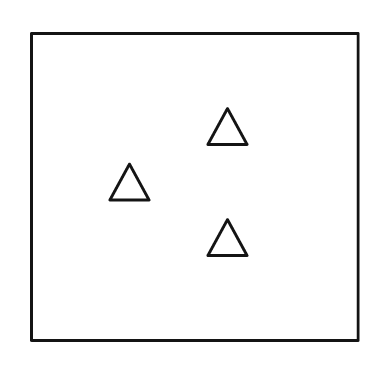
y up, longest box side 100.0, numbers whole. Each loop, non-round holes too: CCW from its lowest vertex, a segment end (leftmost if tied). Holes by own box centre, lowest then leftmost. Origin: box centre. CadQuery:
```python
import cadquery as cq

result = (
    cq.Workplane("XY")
    .moveTo(-50.0, -47.0)
    .lineTo(50.0, -47.0)
    .lineTo(50.0, 47.0)
    .lineTo(-50.0, 47.0)
    .close()
    .moveTo(4.0, -21.0)
    .lineTo(16.0, -21.0)
    .lineTo(10.0, -10.0)
    .close()
    .moveTo(-26.0, -4.0)
    .lineTo(-14.0, -4.0)
    .lineTo(-20.0, 7.0)
    .close()
    .moveTo(4.0, 13.0)
    .lineTo(16.0, 13.0)
    .lineTo(10.0, 24.0)
    .close()
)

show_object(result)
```